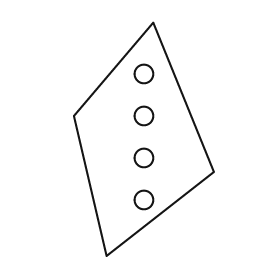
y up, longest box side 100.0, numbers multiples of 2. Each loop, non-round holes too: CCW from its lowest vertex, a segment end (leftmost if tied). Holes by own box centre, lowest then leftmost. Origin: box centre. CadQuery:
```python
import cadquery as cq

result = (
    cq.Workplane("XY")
    .moveTo(-16.0, -50.0)
    .lineTo(30.0, -14.0)
    .lineTo(4.0, 50.0)
    .lineTo(-30.0, 10.0)
    .close()
    .moveTo(0.0, -26.0)
    .circle(4.0)
    .moveTo(0.0, -8.0)
    .circle(4.0)
    .moveTo(0.0, 10.0)
    .circle(4.0)
    .moveTo(0.0, 28.0)
    .circle(4.0)
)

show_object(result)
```